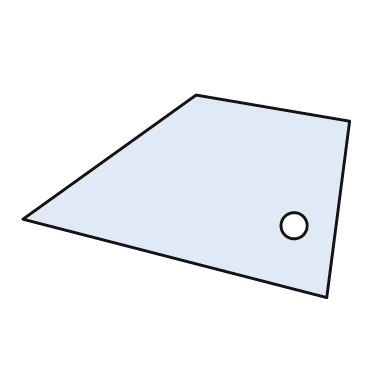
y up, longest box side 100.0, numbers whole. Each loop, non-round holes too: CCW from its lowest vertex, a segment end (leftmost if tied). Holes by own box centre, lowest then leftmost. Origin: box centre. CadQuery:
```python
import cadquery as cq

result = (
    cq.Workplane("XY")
    .moveTo(43.0, -31.0)
    .lineTo(50.0, 23.0)
    .lineTo(3.0, 31.0)
    .lineTo(-50.0, -7.0)
    .close()
    .moveTo(33.0, -9.0)
    .circle(4.0)
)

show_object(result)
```